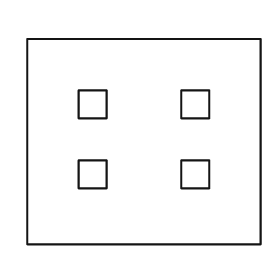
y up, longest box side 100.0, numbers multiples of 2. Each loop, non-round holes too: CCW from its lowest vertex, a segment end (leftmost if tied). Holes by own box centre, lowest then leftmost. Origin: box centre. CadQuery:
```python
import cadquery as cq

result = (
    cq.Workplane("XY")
    .moveTo(-50.0, -44.0)
    .lineTo(50.0, -44.0)
    .lineTo(50.0, 44.0)
    .lineTo(-50.0, 44.0)
    .close()
    .moveTo(-28.0, -20.0)
    .lineTo(-16.0, -20.0)
    .lineTo(-16.0, -8.0)
    .lineTo(-28.0, -8.0)
    .close()
    .moveTo(16.0, -20.0)
    .lineTo(28.0, -20.0)
    .lineTo(28.0, -8.0)
    .lineTo(16.0, -8.0)
    .close()
    .moveTo(-28.0, 10.0)
    .lineTo(-16.0, 10.0)
    .lineTo(-16.0, 22.0)
    .lineTo(-28.0, 22.0)
    .close()
    .moveTo(16.0, 10.0)
    .lineTo(28.0, 10.0)
    .lineTo(28.0, 22.0)
    .lineTo(16.0, 22.0)
    .close()
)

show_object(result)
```